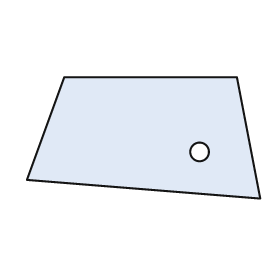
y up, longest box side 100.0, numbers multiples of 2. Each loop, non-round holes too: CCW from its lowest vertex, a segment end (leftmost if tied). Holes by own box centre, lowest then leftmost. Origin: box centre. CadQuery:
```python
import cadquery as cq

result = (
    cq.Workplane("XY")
    .moveTo(50.0, -26.0)
    .lineTo(40.0, 26.0)
    .lineTo(-34.0, 26.0)
    .lineTo(-50.0, -18.0)
    .close()
    .moveTo(24.0, -6.0)
    .circle(4.0)
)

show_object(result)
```